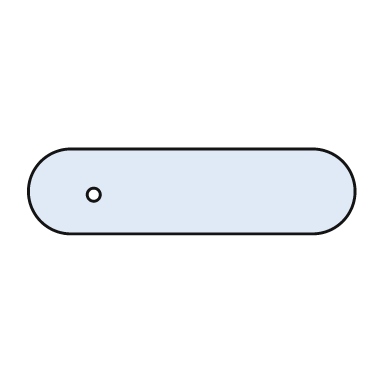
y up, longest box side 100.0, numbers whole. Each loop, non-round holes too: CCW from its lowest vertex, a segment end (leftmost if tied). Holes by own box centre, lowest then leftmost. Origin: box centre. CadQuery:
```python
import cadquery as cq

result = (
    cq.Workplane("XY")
    .moveTo(-37.0, -13.0)
    .lineTo(37.0, -13.0)
    .threePointArc((50.0, 0.0), (37.0, 13.0))
    .lineTo(-37.0, 13.0)
    .threePointArc((-50.0, 0.0), (-37.0, -13.0))
    .close()
    .moveTo(-30.0, -1.0)
    .circle(2.0)
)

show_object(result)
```